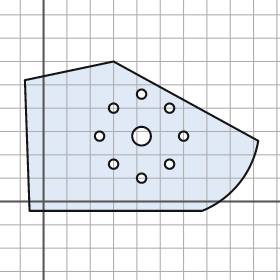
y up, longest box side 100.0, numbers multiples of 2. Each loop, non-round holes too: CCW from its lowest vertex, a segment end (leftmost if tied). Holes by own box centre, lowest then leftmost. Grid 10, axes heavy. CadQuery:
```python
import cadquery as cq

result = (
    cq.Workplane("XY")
    .moveTo(-6.0, -4.0)
    .lineTo(68.0, -4.0)
    .threePointArc((84.0, 8.0), (92.0, 26.0))
    .lineTo(30.0, 60.0)
    .lineTo(-8.0, 52.0)
    .close()
    .moveTo(42.0, 10.0)
    .circle(2.0)
    .moveTo(30.0, 16.0)
    .circle(2.0)
    .moveTo(54.0, 16.0)
    .circle(2.0)
    .moveTo(24.0, 28.0)
    .circle(2.0)
    .moveTo(42.0, 28.0)
    .circle(4.0)
    .moveTo(60.0, 28.0)
    .circle(2.0)
    .moveTo(30.0, 40.0)
    .circle(2.0)
    .moveTo(54.0, 40.0)
    .circle(2.0)
    .moveTo(42.0, 46.0)
    .circle(2.0)
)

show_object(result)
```